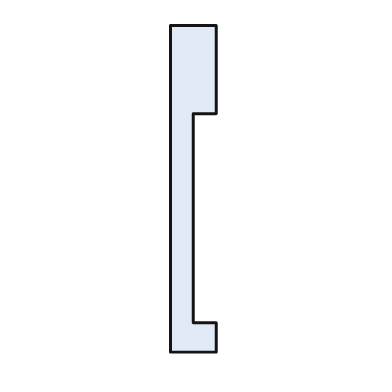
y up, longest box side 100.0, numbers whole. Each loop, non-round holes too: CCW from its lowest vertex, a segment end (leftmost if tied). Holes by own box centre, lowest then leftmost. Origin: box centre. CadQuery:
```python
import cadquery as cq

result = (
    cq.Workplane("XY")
    .moveTo(-7.0, -50.0)
    .lineTo(7.0, -50.0)
    .lineTo(7.0, -41.0)
    .lineTo(0.0, -41.0)
    .lineTo(0.0, 23.0)
    .lineTo(7.0, 23.0)
    .lineTo(7.0, 50.0)
    .lineTo(-7.0, 50.0)
    .close()
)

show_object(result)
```